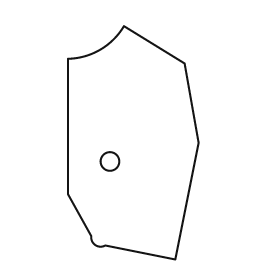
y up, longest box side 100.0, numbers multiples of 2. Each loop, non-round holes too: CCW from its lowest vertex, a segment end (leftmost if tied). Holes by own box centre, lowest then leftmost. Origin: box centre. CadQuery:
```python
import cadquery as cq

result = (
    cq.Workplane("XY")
    .moveTo(18.0, -50.0)
    .lineTo(28.0, 0.0)
    .lineTo(22.0, 34.0)
    .lineTo(-4.0, 50.0)
    .threePointArc((-14.0, 40.0), (-28.0, 36.0))
    .lineTo(-28.0, -22.0)
    .lineTo(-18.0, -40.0)
    .threePointArc((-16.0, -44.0), (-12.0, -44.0))
    .close()
    .moveTo(-10.0, -8.0)
    .circle(4.0)
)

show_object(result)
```